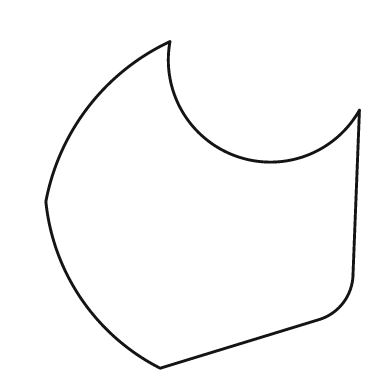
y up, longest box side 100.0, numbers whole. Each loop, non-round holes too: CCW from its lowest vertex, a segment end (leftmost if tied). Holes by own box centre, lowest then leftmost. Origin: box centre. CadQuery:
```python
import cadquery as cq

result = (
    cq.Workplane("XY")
    .moveTo(-13.0, -50.0)
    .lineTo(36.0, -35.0)
    .threePointArc((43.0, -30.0), (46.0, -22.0))
    .lineTo(48.0, 29.0)
    .threePointArc((10.0, 15.0), (-10.0, 50.0))
    .threePointArc((-35.0, 30.0), (-48.0, 1.0))
    .threePointArc((-37.0, -29.0), (-13.0, -50.0))
    .close()
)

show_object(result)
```